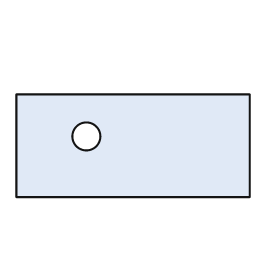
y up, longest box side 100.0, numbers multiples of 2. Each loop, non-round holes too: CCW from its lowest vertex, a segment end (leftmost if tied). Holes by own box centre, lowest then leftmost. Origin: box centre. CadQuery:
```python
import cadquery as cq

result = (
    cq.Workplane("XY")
    .moveTo(-50.0, -22.0)
    .lineTo(50.0, -22.0)
    .lineTo(50.0, 22.0)
    .lineTo(-50.0, 22.0)
    .close()
    .moveTo(-20.0, 4.0)
    .circle(6.0)
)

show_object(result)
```